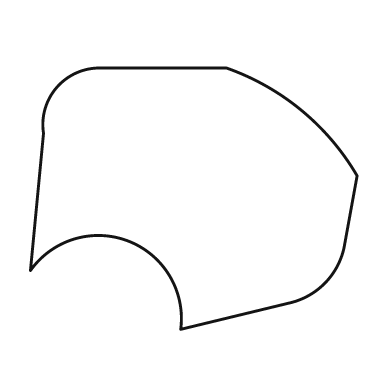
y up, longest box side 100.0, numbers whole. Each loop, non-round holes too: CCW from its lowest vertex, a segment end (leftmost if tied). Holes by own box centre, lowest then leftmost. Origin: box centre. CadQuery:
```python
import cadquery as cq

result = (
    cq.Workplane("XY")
    .moveTo(-4.0, -40.0)
    .lineTo(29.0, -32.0)
    .threePointArc((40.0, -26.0), (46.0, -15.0))
    .lineTo(50.0, 7.0)
    .threePointArc((33.0, 27.0), (10.0, 40.0))
    .lineTo(-29.0, 40.0)
    .threePointArc((-42.0, 34.0), (-46.0, 20.0))
    .lineTo(-50.0, -22.0)
    .threePointArc((-20.0, -13.0), (-4.0, -40.0))
    .close()
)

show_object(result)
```